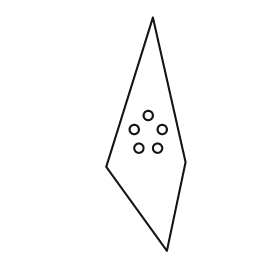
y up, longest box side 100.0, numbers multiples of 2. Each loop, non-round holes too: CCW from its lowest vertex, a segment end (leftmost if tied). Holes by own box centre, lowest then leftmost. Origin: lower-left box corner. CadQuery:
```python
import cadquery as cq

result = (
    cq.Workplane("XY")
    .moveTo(26.0, 0.0)
    .lineTo(34.0, 38.0)
    .lineTo(20.0, 100.0)
    .lineTo(0.0, 36.0)
    .close()
    .moveTo(14.0, 44.0)
    .circle(2.0)
    .moveTo(22.0, 44.0)
    .circle(2.0)
    .moveTo(12.0, 52.0)
    .circle(2.0)
    .moveTo(24.0, 52.0)
    .circle(2.0)
    .moveTo(18.0, 58.0)
    .circle(2.0)
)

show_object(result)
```